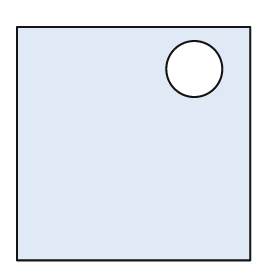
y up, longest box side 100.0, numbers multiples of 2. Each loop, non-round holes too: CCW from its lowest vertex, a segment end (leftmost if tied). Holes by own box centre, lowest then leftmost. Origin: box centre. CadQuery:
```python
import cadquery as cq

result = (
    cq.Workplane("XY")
    .moveTo(-50.0, -50.0)
    .lineTo(50.0, -50.0)
    .lineTo(50.0, 50.0)
    .lineTo(-50.0, 50.0)
    .close()
    .moveTo(26.0, 32.0)
    .circle(12.0)
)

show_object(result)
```